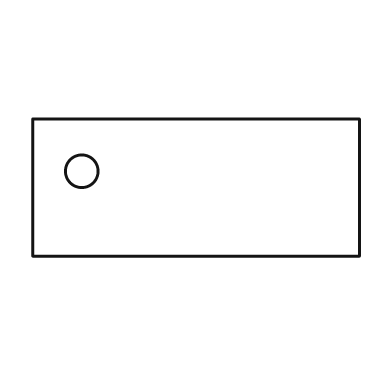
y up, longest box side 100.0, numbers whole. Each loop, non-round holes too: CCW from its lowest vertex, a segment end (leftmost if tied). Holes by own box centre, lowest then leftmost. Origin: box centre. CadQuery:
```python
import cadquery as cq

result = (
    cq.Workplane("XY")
    .moveTo(-50.0, -21.0)
    .lineTo(50.0, -21.0)
    .lineTo(50.0, 21.0)
    .lineTo(-50.0, 21.0)
    .close()
    .moveTo(-35.0, 5.0)
    .circle(5.0)
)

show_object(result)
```